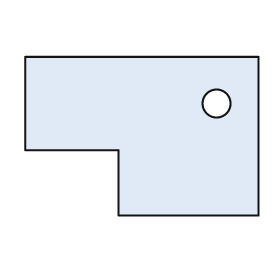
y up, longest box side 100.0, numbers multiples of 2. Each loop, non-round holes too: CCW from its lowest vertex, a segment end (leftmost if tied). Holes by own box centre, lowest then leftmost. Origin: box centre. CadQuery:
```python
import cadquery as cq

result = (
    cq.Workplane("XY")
    .moveTo(-10.0, -34.0)
    .lineTo(50.0, -34.0)
    .lineTo(50.0, 34.0)
    .lineTo(-50.0, 34.0)
    .lineTo(-50.0, -6.0)
    .lineTo(-10.0, -6.0)
    .close()
    .moveTo(32.0, 14.0)
    .circle(6.0)
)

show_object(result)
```